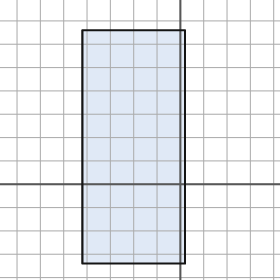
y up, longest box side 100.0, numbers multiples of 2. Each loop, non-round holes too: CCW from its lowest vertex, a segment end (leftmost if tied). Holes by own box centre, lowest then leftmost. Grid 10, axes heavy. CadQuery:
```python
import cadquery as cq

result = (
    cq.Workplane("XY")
    .moveTo(-42.0, -34.0)
    .lineTo(2.0, -34.0)
    .lineTo(2.0, 66.0)
    .lineTo(-42.0, 66.0)
    .close()
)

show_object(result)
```